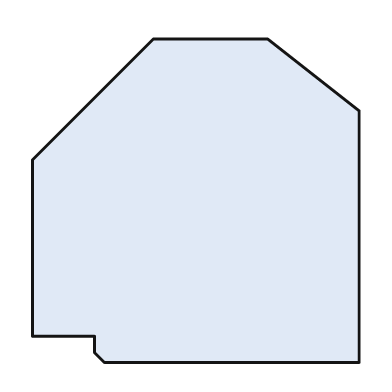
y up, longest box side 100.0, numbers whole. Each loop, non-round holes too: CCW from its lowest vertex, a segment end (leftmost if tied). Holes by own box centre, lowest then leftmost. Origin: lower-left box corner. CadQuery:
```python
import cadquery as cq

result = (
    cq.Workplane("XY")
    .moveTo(22.0, 0.0)
    .lineTo(100.0, 0.0)
    .lineTo(100.0, 77.0)
    .lineTo(72.0, 99.0)
    .lineTo(37.0, 99.0)
    .lineTo(0.0, 62.0)
    .lineTo(0.0, 8.0)
    .lineTo(19.0, 8.0)
    .lineTo(19.0, 3.0)
    .close()
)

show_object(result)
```